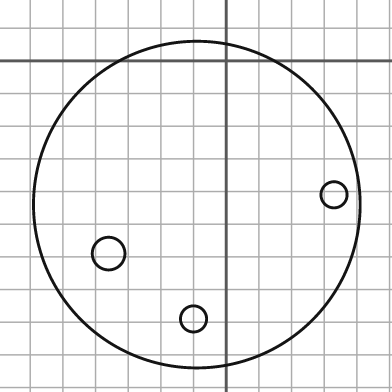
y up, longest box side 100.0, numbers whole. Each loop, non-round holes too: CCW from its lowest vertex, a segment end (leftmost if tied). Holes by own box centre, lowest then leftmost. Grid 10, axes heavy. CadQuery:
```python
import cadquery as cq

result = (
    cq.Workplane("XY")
    .moveTo(-9.0, -44.0)
    .circle(50.0)
    .moveTo(-10.0, -79.0)
    .circle(4.0)
    .moveTo(-36.0, -59.0)
    .circle(5.0)
    .moveTo(33.0, -41.0)
    .circle(4.0)
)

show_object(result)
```